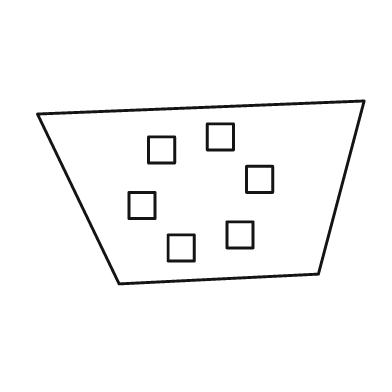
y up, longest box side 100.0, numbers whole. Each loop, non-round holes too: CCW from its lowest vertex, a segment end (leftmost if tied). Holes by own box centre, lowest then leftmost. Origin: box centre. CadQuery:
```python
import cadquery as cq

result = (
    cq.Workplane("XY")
    .moveTo(-25.0, -28.0)
    .lineTo(36.0, -25.0)
    .lineTo(50.0, 28.0)
    .lineTo(-50.0, 24.0)
    .close()
    .moveTo(-10.0, -21.0)
    .lineTo(-2.0, -21.0)
    .lineTo(-2.0, -13.0)
    .lineTo(-10.0, -13.0)
    .close()
    .moveTo(8.0, -17.0)
    .lineTo(16.0, -17.0)
    .lineTo(16.0, -9.0)
    .lineTo(8.0, -9.0)
    .close()
    .moveTo(-22.0, -8.0)
    .lineTo(-14.0, -8.0)
    .lineTo(-14.0, 0.0)
    .lineTo(-22.0, 0.0)
    .close()
    .moveTo(14.0, 0.0)
    .lineTo(22.0, 0.0)
    .lineTo(22.0, 8.0)
    .lineTo(14.0, 8.0)
    .close()
    .moveTo(-16.0, 9.0)
    .lineTo(-8.0, 9.0)
    .lineTo(-8.0, 17.0)
    .lineTo(-16.0, 17.0)
    .close()
    .moveTo(2.0, 13.0)
    .lineTo(10.0, 13.0)
    .lineTo(10.0, 21.0)
    .lineTo(2.0, 21.0)
    .close()
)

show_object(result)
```